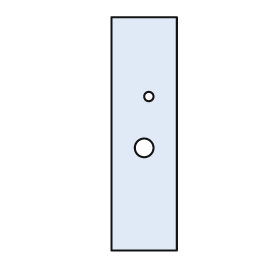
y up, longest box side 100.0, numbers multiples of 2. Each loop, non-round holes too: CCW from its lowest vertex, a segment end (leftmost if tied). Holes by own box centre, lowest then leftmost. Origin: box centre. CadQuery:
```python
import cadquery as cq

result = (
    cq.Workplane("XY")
    .moveTo(-14.0, -50.0)
    .lineTo(14.0, -50.0)
    .lineTo(14.0, 50.0)
    .lineTo(-14.0, 50.0)
    .close()
    .moveTo(0.0, -6.0)
    .circle(4.0)
    .moveTo(2.0, 16.0)
    .circle(2.0)
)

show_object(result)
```